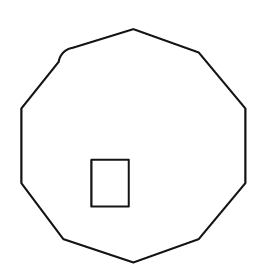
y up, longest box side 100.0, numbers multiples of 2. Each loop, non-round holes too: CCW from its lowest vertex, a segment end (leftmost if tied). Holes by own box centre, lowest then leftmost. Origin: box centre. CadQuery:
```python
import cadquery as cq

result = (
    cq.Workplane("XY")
    .moveTo(0.0, -50.0)
    .lineTo(28.0, -40.0)
    .lineTo(48.0, -16.0)
    .lineTo(48.0, 16.0)
    .lineTo(28.0, 40.0)
    .lineTo(0.0, 50.0)
    .lineTo(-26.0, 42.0)
    .threePointArc((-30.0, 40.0), (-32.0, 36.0))
    .lineTo(-48.0, 16.0)
    .lineTo(-48.0, -16.0)
    .lineTo(-30.0, -40.0)
    .close()
    .moveTo(-18.0, -26.0)
    .lineTo(-2.0, -26.0)
    .lineTo(-2.0, -6.0)
    .lineTo(-18.0, -6.0)
    .close()
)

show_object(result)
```